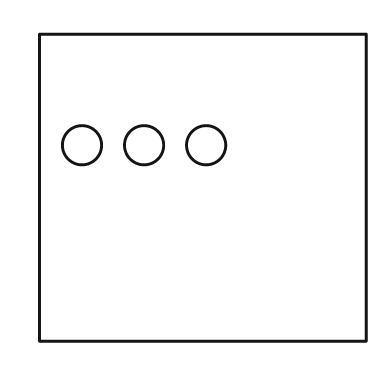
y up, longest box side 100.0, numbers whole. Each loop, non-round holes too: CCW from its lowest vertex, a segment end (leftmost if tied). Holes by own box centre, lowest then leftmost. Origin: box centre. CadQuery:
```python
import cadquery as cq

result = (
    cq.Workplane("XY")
    .moveTo(-50.0, -47.0)
    .lineTo(50.0, -47.0)
    .lineTo(50.0, 47.0)
    .lineTo(-50.0, 47.0)
    .close()
    .moveTo(-37.0, 13.0)
    .circle(6.0)
    .moveTo(-18.0, 13.0)
    .circle(6.0)
    .moveTo(1.0, 13.0)
    .circle(6.0)
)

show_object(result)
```